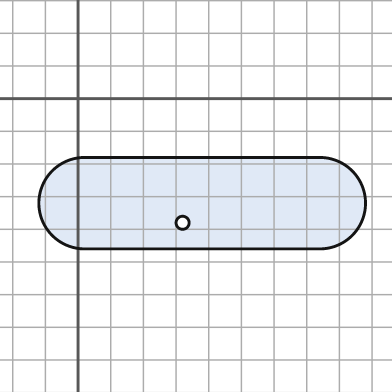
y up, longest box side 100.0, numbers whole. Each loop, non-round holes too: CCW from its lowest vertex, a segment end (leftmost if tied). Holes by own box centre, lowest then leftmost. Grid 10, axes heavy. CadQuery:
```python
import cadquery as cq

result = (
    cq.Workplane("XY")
    .moveTo(2.0, -46.0)
    .lineTo(74.0, -46.0)
    .threePointArc((88.0, -32.0), (74.0, -18.0))
    .lineTo(2.0, -18.0)
    .threePointArc((-12.0, -32.0), (2.0, -46.0))
    .close()
    .moveTo(32.0, -38.0)
    .circle(2.0)
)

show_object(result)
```